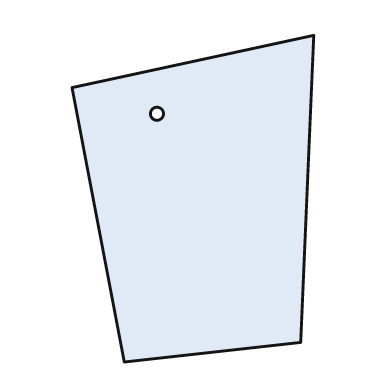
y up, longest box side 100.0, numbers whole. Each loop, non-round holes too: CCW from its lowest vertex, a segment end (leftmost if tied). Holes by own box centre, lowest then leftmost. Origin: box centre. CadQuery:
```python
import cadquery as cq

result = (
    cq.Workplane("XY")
    .moveTo(-21.0, -50.0)
    .lineTo(33.0, -44.0)
    .lineTo(37.0, 50.0)
    .lineTo(-37.0, 34.0)
    .close()
    .moveTo(-11.0, 26.0)
    .circle(2.0)
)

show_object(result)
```